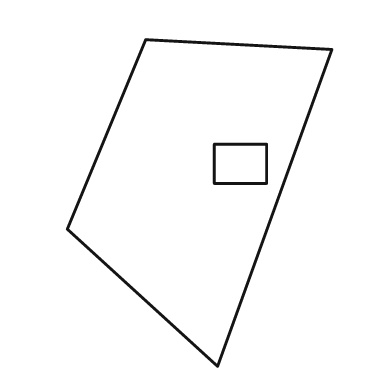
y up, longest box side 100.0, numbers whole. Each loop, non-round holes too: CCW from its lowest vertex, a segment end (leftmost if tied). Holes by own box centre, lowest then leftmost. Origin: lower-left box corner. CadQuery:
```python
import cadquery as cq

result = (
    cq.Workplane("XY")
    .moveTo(46.0, 0.0)
    .lineTo(81.0, 97.0)
    .lineTo(24.0, 100.0)
    .lineTo(0.0, 42.0)
    .close()
    .moveTo(45.0, 56.0)
    .lineTo(61.0, 56.0)
    .lineTo(61.0, 68.0)
    .lineTo(45.0, 68.0)
    .close()
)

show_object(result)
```